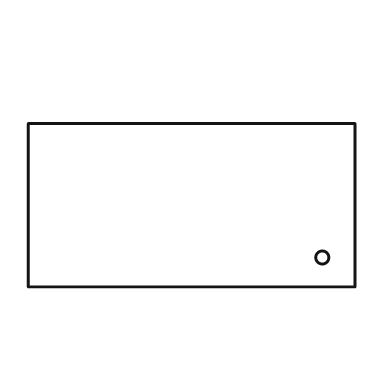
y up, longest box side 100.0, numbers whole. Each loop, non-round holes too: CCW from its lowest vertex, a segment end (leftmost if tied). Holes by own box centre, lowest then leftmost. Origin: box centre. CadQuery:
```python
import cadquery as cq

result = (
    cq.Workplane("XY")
    .moveTo(-50.0, -25.0)
    .lineTo(50.0, -25.0)
    .lineTo(50.0, 25.0)
    .lineTo(-50.0, 25.0)
    .close()
    .moveTo(40.0, -16.0)
    .circle(2.0)
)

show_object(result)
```